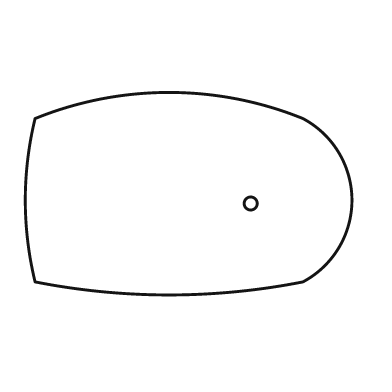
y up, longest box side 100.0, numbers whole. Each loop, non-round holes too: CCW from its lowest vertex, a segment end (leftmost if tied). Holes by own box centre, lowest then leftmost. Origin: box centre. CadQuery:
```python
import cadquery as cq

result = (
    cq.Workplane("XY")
    .moveTo(-47.0, -27.0)
    .threePointArc((-6.0, -31.0), (35.0, -27.0))
    .threePointArc((50.0, -2.0), (35.0, 23.0))
    .threePointArc((-6.0, 31.0), (-47.0, 23.0))
    .threePointArc((-50.0, -2.0), (-47.0, -27.0))
    .close()
    .moveTo(19.0, -3.0)
    .circle(2.0)
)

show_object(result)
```